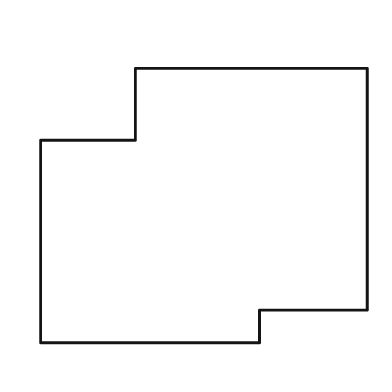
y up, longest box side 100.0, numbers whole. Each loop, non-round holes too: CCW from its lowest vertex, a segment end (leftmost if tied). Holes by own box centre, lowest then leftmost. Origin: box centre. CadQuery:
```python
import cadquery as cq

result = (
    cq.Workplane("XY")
    .moveTo(-50.0, -42.0)
    .lineTo(17.0, -42.0)
    .lineTo(17.0, -32.0)
    .lineTo(50.0, -32.0)
    .lineTo(50.0, 42.0)
    .lineTo(-21.0, 42.0)
    .lineTo(-21.0, 20.0)
    .lineTo(-50.0, 20.0)
    .close()
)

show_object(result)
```